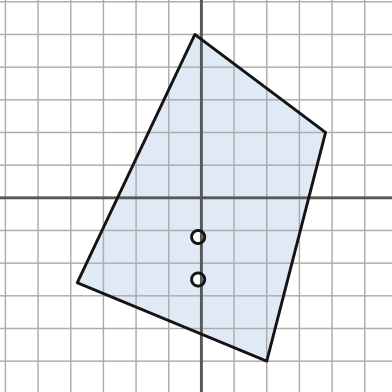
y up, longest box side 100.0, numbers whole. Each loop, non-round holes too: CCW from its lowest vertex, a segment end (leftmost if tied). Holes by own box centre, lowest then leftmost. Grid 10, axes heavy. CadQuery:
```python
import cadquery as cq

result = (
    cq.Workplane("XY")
    .moveTo(20.0, -50.0)
    .lineTo(38.0, 20.0)
    .lineTo(-2.0, 50.0)
    .lineTo(-38.0, -26.0)
    .close()
    .moveTo(-1.0, -25.0)
    .circle(2.0)
    .moveTo(-1.0, -12.0)
    .circle(2.0)
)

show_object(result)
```